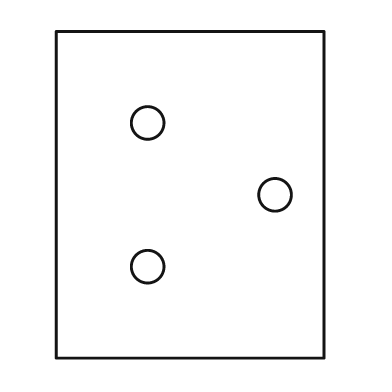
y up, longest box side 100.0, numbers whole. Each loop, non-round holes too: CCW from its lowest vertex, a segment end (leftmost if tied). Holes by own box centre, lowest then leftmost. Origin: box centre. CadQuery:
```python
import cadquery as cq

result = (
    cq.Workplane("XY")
    .moveTo(-41.0, -50.0)
    .lineTo(41.0, -50.0)
    .lineTo(41.0, 50.0)
    .lineTo(-41.0, 50.0)
    .close()
    .moveTo(-13.0, -22.0)
    .circle(5.0)
    .moveTo(26.0, 0.0)
    .circle(5.0)
    .moveTo(-13.0, 22.0)
    .circle(5.0)
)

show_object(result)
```